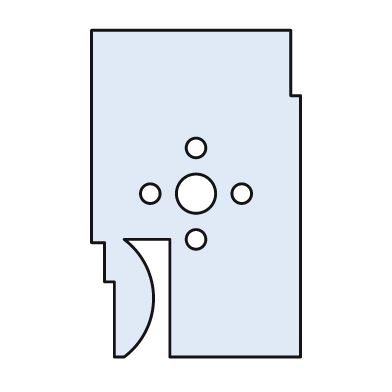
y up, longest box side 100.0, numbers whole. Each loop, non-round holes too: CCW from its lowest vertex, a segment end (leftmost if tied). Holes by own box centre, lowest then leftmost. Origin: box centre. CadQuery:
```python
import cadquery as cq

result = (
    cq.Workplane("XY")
    .moveTo(-25.0, -50.0)
    .lineTo(-22.0, -50.0)
    .threePointArc((-13.0, -32.0), (-22.0, -14.0))
    .lineTo(-8.0, -14.0)
    .lineTo(-8.0, -50.0)
    .lineTo(32.0, -50.0)
    .lineTo(32.0, 30.0)
    .lineTo(29.0, 30.0)
    .lineTo(29.0, 50.0)
    .lineTo(-32.0, 50.0)
    .lineTo(-32.0, -15.0)
    .lineTo(-28.0, -15.0)
    .lineTo(-28.0, -27.0)
    .lineTo(-25.0, -27.0)
    .close()
    .moveTo(0.0, -14.0)
    .circle(3.0)
    .moveTo(-14.0, 0.0)
    .circle(3.0)
    .moveTo(0.0, 0.0)
    .circle(6.0)
    .moveTo(14.0, 0.0)
    .circle(3.0)
    .moveTo(0.0, 14.0)
    .circle(3.0)
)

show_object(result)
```